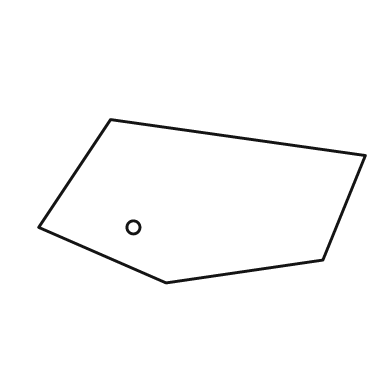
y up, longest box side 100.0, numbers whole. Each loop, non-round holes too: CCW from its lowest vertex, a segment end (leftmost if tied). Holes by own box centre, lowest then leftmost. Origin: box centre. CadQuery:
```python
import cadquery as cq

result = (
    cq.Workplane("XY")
    .moveTo(-11.0, -25.0)
    .lineTo(37.0, -18.0)
    .lineTo(50.0, 14.0)
    .lineTo(-28.0, 25.0)
    .lineTo(-50.0, -8.0)
    .close()
    .moveTo(-21.0, -8.0)
    .circle(2.0)
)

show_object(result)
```